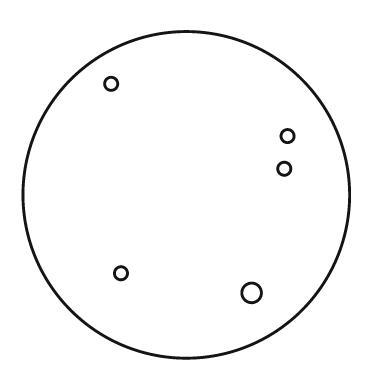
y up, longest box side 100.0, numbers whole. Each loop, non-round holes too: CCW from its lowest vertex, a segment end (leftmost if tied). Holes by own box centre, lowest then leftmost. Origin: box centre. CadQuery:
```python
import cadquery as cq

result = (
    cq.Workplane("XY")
    .moveTo(0.0, 0.0)
    .circle(50.0)
    .moveTo(20.0, -30.0)
    .circle(3.0)
    .moveTo(-20.0, -24.0)
    .circle(2.0)
    .moveTo(30.0, 8.0)
    .circle(2.0)
    .moveTo(31.0, 18.0)
    .circle(2.0)
    .moveTo(-23.0, 34.0)
    .circle(2.0)
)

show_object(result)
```